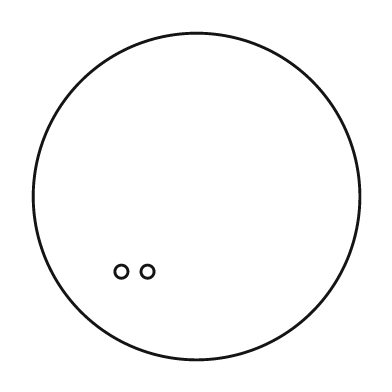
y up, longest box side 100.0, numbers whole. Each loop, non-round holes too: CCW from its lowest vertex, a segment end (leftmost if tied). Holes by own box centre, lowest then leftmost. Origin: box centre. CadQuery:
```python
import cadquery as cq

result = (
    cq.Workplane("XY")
    .moveTo(0.0, 0.0)
    .circle(50.0)
    .moveTo(-23.0, -23.0)
    .circle(2.0)
    .moveTo(-15.0, -23.0)
    .circle(2.0)
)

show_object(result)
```